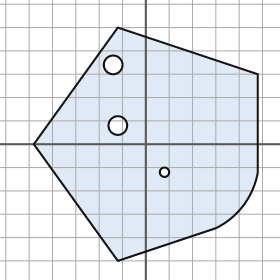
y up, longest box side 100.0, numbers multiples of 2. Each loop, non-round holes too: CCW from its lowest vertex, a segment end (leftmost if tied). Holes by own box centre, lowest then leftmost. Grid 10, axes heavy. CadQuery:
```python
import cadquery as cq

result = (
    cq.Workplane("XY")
    .moveTo(-12.0, -50.0)
    .lineTo(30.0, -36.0)
    .threePointArc((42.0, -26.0), (48.0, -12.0))
    .lineTo(48.0, 30.0)
    .lineTo(-12.0, 50.0)
    .lineTo(-48.0, 0.0)
    .close()
    .moveTo(8.0, -12.0)
    .circle(2.0)
    .moveTo(-12.0, 8.0)
    .circle(4.0)
    .moveTo(-14.0, 34.0)
    .circle(4.0)
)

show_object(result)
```